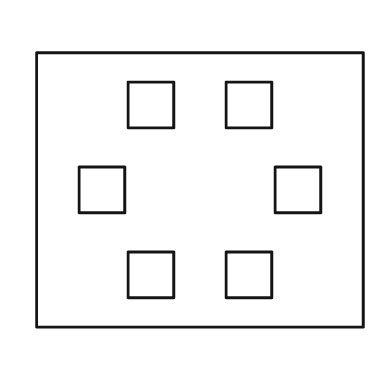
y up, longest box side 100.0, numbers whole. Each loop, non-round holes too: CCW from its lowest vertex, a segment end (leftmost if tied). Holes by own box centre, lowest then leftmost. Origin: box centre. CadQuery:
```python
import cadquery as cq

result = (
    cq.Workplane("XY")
    .moveTo(-50.0, -42.0)
    .lineTo(50.0, -42.0)
    .lineTo(50.0, 42.0)
    .lineTo(-50.0, 42.0)
    .close()
    .moveTo(-22.0, -33.0)
    .lineTo(-8.0, -33.0)
    .lineTo(-8.0, -19.0)
    .lineTo(-22.0, -19.0)
    .close()
    .moveTo(8.0, -33.0)
    .lineTo(22.0, -33.0)
    .lineTo(22.0, -19.0)
    .lineTo(8.0, -19.0)
    .close()
    .moveTo(-37.0, -7.0)
    .lineTo(-23.0, -7.0)
    .lineTo(-23.0, 7.0)
    .lineTo(-37.0, 7.0)
    .close()
    .moveTo(23.0, -7.0)
    .lineTo(37.0, -7.0)
    .lineTo(37.0, 7.0)
    .lineTo(23.0, 7.0)
    .close()
    .moveTo(-22.0, 19.0)
    .lineTo(-8.0, 19.0)
    .lineTo(-8.0, 33.0)
    .lineTo(-22.0, 33.0)
    .close()
    .moveTo(8.0, 19.0)
    .lineTo(22.0, 19.0)
    .lineTo(22.0, 33.0)
    .lineTo(8.0, 33.0)
    .close()
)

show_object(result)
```